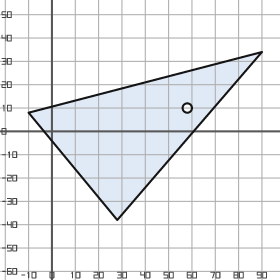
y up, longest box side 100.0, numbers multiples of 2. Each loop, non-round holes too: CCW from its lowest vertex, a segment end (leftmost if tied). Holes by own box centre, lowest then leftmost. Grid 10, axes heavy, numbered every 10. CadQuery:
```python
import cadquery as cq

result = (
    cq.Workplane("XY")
    .moveTo(28.0, -38.0)
    .lineTo(90.0, 34.0)
    .lineTo(-10.0, 8.0)
    .close()
    .moveTo(58.0, 10.0)
    .circle(2.0)
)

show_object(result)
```